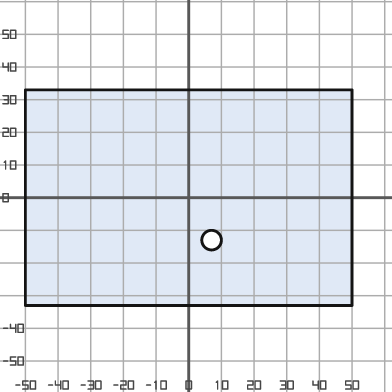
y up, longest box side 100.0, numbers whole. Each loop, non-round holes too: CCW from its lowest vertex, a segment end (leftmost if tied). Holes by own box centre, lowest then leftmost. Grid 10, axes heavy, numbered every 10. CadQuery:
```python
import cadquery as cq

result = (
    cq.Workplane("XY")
    .moveTo(-50.0, -33.0)
    .lineTo(50.0, -33.0)
    .lineTo(50.0, 33.0)
    .lineTo(-50.0, 33.0)
    .close()
    .moveTo(7.0, -13.0)
    .circle(3.0)
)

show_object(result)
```